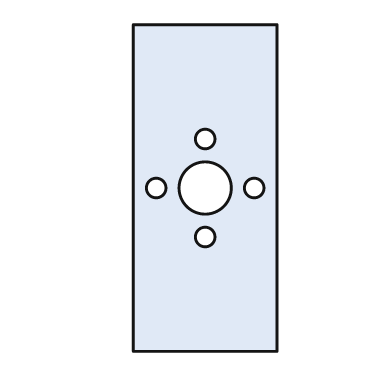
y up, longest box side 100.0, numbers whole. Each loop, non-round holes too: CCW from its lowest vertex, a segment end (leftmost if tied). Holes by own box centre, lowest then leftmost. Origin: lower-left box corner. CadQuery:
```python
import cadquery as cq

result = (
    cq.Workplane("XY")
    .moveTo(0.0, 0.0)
    .lineTo(44.0, 0.0)
    .lineTo(44.0, 100.0)
    .lineTo(0.0, 100.0)
    .close()
    .moveTo(22.0, 35.0)
    .circle(3.0)
    .moveTo(7.0, 50.0)
    .circle(3.0)
    .moveTo(22.0, 50.0)
    .circle(8.0)
    .moveTo(37.0, 50.0)
    .circle(3.0)
    .moveTo(22.0, 65.0)
    .circle(3.0)
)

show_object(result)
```